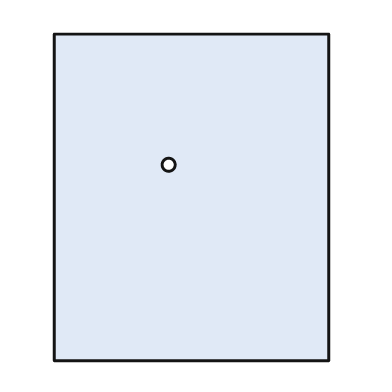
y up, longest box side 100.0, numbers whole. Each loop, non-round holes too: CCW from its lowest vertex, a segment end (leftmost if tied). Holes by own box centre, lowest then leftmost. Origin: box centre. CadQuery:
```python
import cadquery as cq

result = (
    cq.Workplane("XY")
    .moveTo(-42.0, -50.0)
    .lineTo(42.0, -50.0)
    .lineTo(42.0, 50.0)
    .lineTo(-42.0, 50.0)
    .close()
    .moveTo(-7.0, 10.0)
    .circle(2.0)
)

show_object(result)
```